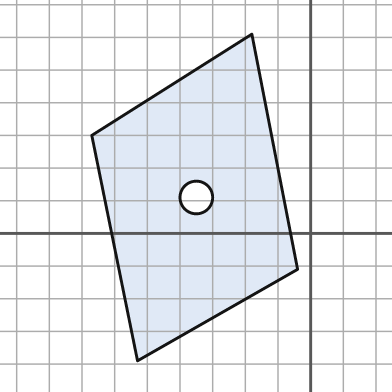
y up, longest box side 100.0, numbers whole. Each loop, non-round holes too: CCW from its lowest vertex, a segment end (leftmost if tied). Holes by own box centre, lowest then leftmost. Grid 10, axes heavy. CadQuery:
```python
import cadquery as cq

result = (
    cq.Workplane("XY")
    .moveTo(-53.0, -39.0)
    .lineTo(-4.0, -11.0)
    .lineTo(-18.0, 61.0)
    .lineTo(-67.0, 30.0)
    .close()
    .moveTo(-35.0, 11.0)
    .circle(5.0)
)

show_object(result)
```